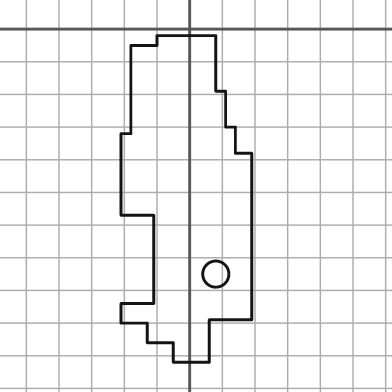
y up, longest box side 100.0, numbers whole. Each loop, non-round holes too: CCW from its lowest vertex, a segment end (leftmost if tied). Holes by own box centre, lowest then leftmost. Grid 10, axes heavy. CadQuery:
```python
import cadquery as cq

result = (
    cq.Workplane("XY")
    .moveTo(-5.0, -102.0)
    .lineTo(6.0, -102.0)
    .lineTo(6.0, -89.0)
    .lineTo(19.0, -89.0)
    .lineTo(19.0, -38.0)
    .lineTo(14.0, -38.0)
    .lineTo(14.0, -30.0)
    .lineTo(11.0, -30.0)
    .lineTo(11.0, -19.0)
    .lineTo(8.0, -19.0)
    .lineTo(8.0, -2.0)
    .lineTo(-10.0, -2.0)
    .lineTo(-10.0, -5.0)
    .lineTo(-18.0, -5.0)
    .lineTo(-18.0, -32.0)
    .lineTo(-21.0, -32.0)
    .lineTo(-21.0, -57.0)
    .lineTo(-11.0, -57.0)
    .lineTo(-11.0, -84.0)
    .lineTo(-21.0, -84.0)
    .lineTo(-21.0, -90.0)
    .lineTo(-13.0, -90.0)
    .lineTo(-13.0, -96.0)
    .lineTo(-5.0, -96.0)
    .close()
    .moveTo(8.0, -75.0)
    .circle(4.0)
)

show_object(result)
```